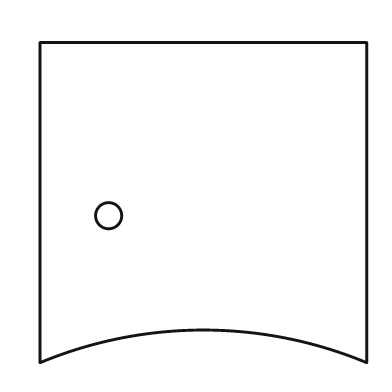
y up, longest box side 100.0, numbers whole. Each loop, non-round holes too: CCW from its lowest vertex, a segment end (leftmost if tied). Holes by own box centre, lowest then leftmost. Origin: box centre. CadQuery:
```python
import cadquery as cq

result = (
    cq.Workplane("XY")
    .moveTo(-50.0, -49.0)
    .threePointArc((0.0, -39.0), (50.0, -49.0))
    .lineTo(50.0, 49.0)
    .lineTo(-50.0, 49.0)
    .close()
    .moveTo(-29.0, -4.0)
    .circle(4.0)
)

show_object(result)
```